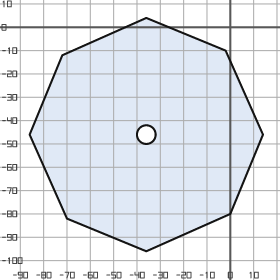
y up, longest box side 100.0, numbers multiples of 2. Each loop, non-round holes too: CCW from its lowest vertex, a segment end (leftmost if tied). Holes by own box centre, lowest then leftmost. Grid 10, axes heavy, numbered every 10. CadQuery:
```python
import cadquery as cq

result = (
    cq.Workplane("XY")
    .moveTo(-36.0, -96.0)
    .lineTo(0.0, -80.0)
    .lineTo(14.0, -46.0)
    .lineTo(-2.0, -10.0)
    .lineTo(-36.0, 4.0)
    .lineTo(-72.0, -12.0)
    .lineTo(-86.0, -46.0)
    .lineTo(-70.0, -82.0)
    .close()
    .moveTo(-36.0, -46.0)
    .circle(4.0)
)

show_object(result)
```